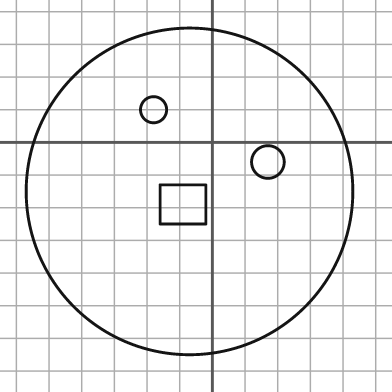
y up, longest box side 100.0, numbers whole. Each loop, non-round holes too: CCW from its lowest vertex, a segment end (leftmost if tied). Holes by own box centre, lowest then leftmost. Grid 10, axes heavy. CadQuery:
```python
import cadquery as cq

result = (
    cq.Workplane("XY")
    .moveTo(-7.0, -15.0)
    .circle(50.0)
    .moveTo(-16.0, -25.0)
    .lineTo(-2.0, -25.0)
    .lineTo(-2.0, -13.0)
    .lineTo(-16.0, -13.0)
    .close()
    .moveTo(17.0, -6.0)
    .circle(5.0)
    .moveTo(-18.0, 10.0)
    .circle(4.0)
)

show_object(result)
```